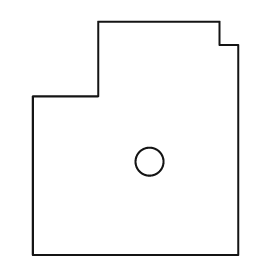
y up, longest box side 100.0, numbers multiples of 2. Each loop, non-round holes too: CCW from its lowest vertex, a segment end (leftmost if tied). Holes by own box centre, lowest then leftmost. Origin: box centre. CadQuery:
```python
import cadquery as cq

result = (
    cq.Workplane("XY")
    .moveTo(-44.0, -50.0)
    .lineTo(44.0, -50.0)
    .lineTo(44.0, 40.0)
    .lineTo(36.0, 40.0)
    .lineTo(36.0, 50.0)
    .lineTo(-16.0, 50.0)
    .lineTo(-16.0, 18.0)
    .lineTo(-44.0, 18.0)
    .close()
    .moveTo(6.0, -10.0)
    .circle(6.0)
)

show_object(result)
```